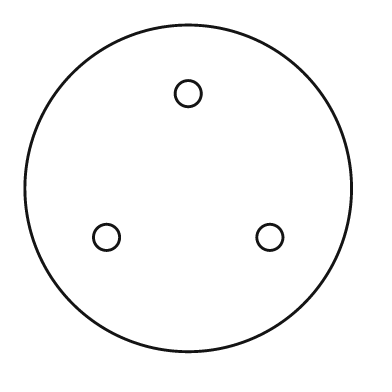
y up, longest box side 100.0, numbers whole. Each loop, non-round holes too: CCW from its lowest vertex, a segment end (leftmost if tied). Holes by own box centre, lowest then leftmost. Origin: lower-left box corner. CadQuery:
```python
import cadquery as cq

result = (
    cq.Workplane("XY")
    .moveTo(50.0, 50.0)
    .circle(50.0)
    .moveTo(25.0, 35.0)
    .circle(4.0)
    .moveTo(75.0, 35.0)
    .circle(4.0)
    .moveTo(50.0, 79.0)
    .circle(4.0)
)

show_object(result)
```